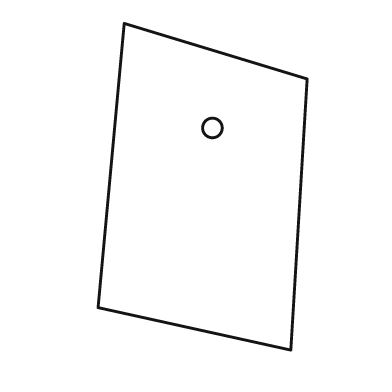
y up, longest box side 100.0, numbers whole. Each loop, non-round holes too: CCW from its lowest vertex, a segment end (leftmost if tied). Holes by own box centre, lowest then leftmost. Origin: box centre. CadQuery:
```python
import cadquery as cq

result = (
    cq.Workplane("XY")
    .moveTo(27.0, -50.0)
    .lineTo(32.0, 33.0)
    .lineTo(-24.0, 50.0)
    .lineTo(-32.0, -37.0)
    .close()
    .moveTo(3.0, 18.0)
    .circle(3.0)
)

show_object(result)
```